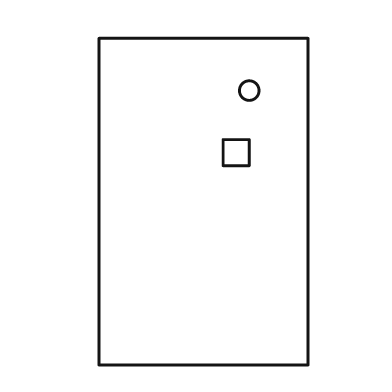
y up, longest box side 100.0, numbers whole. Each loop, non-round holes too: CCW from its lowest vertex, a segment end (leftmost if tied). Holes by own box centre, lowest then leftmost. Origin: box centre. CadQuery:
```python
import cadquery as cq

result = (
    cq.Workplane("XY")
    .moveTo(-32.0, -50.0)
    .lineTo(32.0, -50.0)
    .lineTo(32.0, 50.0)
    .lineTo(-32.0, 50.0)
    .close()
    .moveTo(6.0, 11.0)
    .lineTo(14.0, 11.0)
    .lineTo(14.0, 19.0)
    .lineTo(6.0, 19.0)
    .close()
    .moveTo(14.0, 34.0)
    .circle(3.0)
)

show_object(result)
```